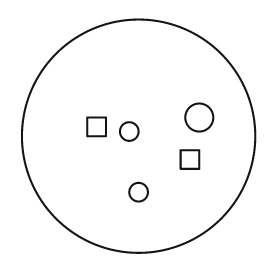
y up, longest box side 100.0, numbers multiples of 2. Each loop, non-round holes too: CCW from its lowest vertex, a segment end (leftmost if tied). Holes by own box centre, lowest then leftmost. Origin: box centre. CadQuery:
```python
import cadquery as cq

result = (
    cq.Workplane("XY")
    .moveTo(0.0, 0.0)
    .circle(50.0)
    .moveTo(0.0, -24.0)
    .circle(4.0)
    .moveTo(18.0, -14.0)
    .lineTo(26.0, -14.0)
    .lineTo(26.0, -6.0)
    .lineTo(18.0, -6.0)
    .close()
    .moveTo(-4.0, 2.0)
    .circle(4.0)
    .moveTo(-22.0, 0.0)
    .lineTo(-14.0, 0.0)
    .lineTo(-14.0, 8.0)
    .lineTo(-22.0, 8.0)
    .close()
    .moveTo(26.0, 8.0)
    .circle(6.0)
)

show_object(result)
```